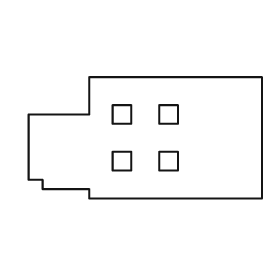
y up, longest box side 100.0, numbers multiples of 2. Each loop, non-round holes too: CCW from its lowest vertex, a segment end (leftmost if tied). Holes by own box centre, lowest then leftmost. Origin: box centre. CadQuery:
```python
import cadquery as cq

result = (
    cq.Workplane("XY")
    .moveTo(-24.0, -26.0)
    .lineTo(50.0, -26.0)
    .lineTo(50.0, 26.0)
    .lineTo(-24.0, 26.0)
    .lineTo(-24.0, 10.0)
    .lineTo(-50.0, 10.0)
    .lineTo(-50.0, -18.0)
    .lineTo(-44.0, -18.0)
    .lineTo(-44.0, -22.0)
    .lineTo(-24.0, -22.0)
    .close()
    .moveTo(-14.0, -14.0)
    .lineTo(-6.0, -14.0)
    .lineTo(-6.0, -6.0)
    .lineTo(-14.0, -6.0)
    .close()
    .moveTo(6.0, -14.0)
    .lineTo(14.0, -14.0)
    .lineTo(14.0, -6.0)
    .lineTo(6.0, -6.0)
    .close()
    .moveTo(-14.0, 6.0)
    .lineTo(-6.0, 6.0)
    .lineTo(-6.0, 14.0)
    .lineTo(-14.0, 14.0)
    .close()
    .moveTo(6.0, 6.0)
    .lineTo(14.0, 6.0)
    .lineTo(14.0, 14.0)
    .lineTo(6.0, 14.0)
    .close()
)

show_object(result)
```